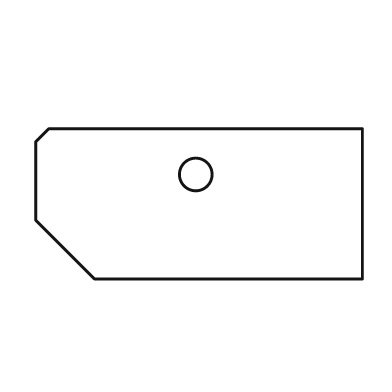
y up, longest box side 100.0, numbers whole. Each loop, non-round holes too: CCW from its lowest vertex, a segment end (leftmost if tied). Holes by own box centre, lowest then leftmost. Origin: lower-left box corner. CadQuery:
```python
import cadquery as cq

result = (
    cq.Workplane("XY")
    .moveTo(18.0, 0.0)
    .lineTo(100.0, 0.0)
    .lineTo(100.0, 46.0)
    .lineTo(4.0, 46.0)
    .lineTo(0.0, 42.0)
    .lineTo(0.0, 18.0)
    .close()
    .moveTo(49.0, 32.0)
    .circle(5.0)
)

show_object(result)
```